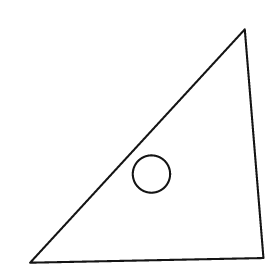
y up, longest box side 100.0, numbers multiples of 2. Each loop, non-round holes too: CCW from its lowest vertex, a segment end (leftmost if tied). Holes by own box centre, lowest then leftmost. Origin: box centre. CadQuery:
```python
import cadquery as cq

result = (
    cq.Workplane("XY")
    .moveTo(-50.0, -50.0)
    .lineTo(50.0, -48.0)
    .lineTo(42.0, 50.0)
    .close()
    .moveTo(2.0, -12.0)
    .circle(8.0)
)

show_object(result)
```